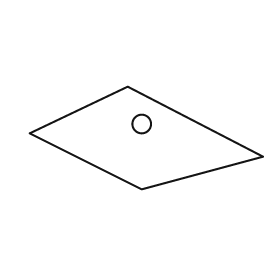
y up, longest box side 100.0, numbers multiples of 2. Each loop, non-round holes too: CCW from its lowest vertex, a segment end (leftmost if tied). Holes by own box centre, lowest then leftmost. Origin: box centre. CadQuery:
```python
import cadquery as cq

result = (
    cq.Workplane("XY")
    .moveTo(-2.0, -22.0)
    .lineTo(50.0, -8.0)
    .lineTo(-8.0, 22.0)
    .lineTo(-50.0, 2.0)
    .close()
    .moveTo(-2.0, 6.0)
    .circle(4.0)
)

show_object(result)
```